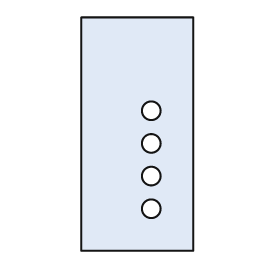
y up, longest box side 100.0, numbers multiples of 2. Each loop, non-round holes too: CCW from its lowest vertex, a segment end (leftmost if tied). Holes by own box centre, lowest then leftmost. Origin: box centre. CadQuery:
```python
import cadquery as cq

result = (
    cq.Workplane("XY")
    .moveTo(-24.0, -50.0)
    .lineTo(24.0, -50.0)
    .lineTo(24.0, 50.0)
    .lineTo(-24.0, 50.0)
    .close()
    .moveTo(6.0, -32.0)
    .circle(4.0)
    .moveTo(6.0, -18.0)
    .circle(4.0)
    .moveTo(6.0, -4.0)
    .circle(4.0)
    .moveTo(6.0, 10.0)
    .circle(4.0)
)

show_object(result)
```